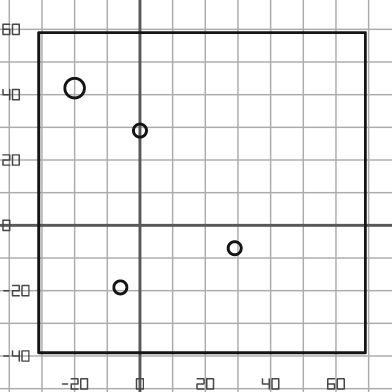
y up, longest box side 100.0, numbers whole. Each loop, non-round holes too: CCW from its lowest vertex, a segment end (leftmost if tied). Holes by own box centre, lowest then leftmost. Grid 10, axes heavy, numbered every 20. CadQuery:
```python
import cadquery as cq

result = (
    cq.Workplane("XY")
    .moveTo(-31.0, -39.0)
    .lineTo(69.0, -39.0)
    .lineTo(69.0, 59.0)
    .lineTo(-31.0, 59.0)
    .close()
    .moveTo(-6.0, -19.0)
    .circle(2.0)
    .moveTo(29.0, -7.0)
    .circle(2.0)
    .moveTo(0.0, 29.0)
    .circle(2.0)
    .moveTo(-20.0, 42.0)
    .circle(3.0)
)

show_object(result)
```